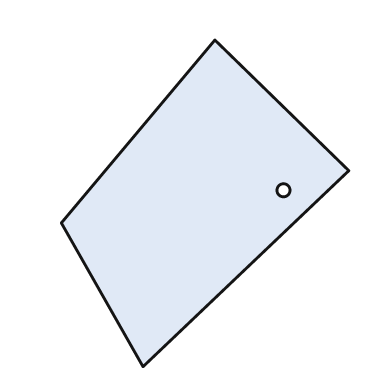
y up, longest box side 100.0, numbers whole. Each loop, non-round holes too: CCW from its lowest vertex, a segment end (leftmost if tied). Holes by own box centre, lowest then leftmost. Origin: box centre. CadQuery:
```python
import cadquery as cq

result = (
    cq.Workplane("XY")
    .moveTo(-19.0, -50.0)
    .lineTo(44.0, 10.0)
    .lineTo(3.0, 50.0)
    .lineTo(-44.0, -6.0)
    .close()
    .moveTo(24.0, 4.0)
    .circle(2.0)
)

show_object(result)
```